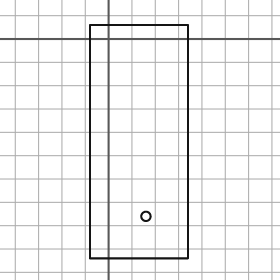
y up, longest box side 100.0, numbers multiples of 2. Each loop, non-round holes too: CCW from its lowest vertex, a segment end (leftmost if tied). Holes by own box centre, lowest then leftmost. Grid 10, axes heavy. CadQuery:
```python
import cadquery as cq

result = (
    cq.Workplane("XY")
    .moveTo(-8.0, -94.0)
    .lineTo(34.0, -94.0)
    .lineTo(34.0, 6.0)
    .lineTo(-8.0, 6.0)
    .close()
    .moveTo(16.0, -76.0)
    .circle(2.0)
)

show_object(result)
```